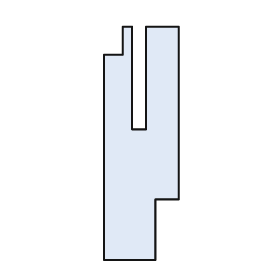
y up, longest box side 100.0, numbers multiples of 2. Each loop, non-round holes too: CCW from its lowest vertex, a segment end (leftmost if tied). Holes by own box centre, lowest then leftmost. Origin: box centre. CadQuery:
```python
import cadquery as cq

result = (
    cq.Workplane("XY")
    .moveTo(-16.0, -50.0)
    .lineTo(6.0, -50.0)
    .lineTo(6.0, -24.0)
    .lineTo(16.0, -24.0)
    .lineTo(16.0, 50.0)
    .lineTo(2.0, 50.0)
    .lineTo(2.0, 6.0)
    .lineTo(-4.0, 6.0)
    .lineTo(-4.0, 50.0)
    .lineTo(-8.0, 50.0)
    .lineTo(-8.0, 38.0)
    .lineTo(-16.0, 38.0)
    .close()
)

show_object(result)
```